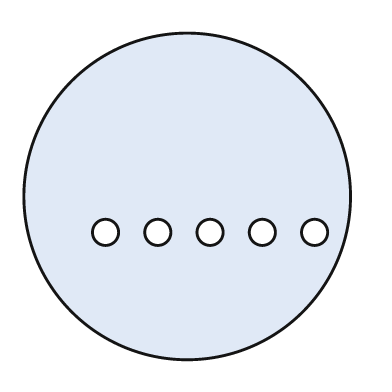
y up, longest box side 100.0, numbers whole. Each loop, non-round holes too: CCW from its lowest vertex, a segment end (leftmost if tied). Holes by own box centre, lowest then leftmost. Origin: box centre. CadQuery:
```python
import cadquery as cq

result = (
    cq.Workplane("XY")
    .moveTo(0.0, 0.0)
    .circle(50.0)
    .moveTo(-25.0, -11.0)
    .circle(4.0)
    .moveTo(-9.0, -11.0)
    .circle(4.0)
    .moveTo(7.0, -11.0)
    .circle(4.0)
    .moveTo(23.0, -11.0)
    .circle(4.0)
    .moveTo(39.0, -11.0)
    .circle(4.0)
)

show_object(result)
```